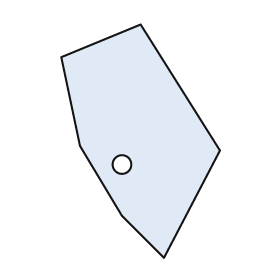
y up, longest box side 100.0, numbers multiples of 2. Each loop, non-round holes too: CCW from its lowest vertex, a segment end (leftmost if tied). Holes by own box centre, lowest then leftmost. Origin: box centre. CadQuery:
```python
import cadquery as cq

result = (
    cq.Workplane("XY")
    .moveTo(10.0, -50.0)
    .lineTo(34.0, -4.0)
    .lineTo(0.0, 50.0)
    .lineTo(-34.0, 36.0)
    .lineTo(-26.0, -2.0)
    .lineTo(-8.0, -32.0)
    .close()
    .moveTo(-8.0, -10.0)
    .circle(4.0)
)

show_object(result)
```